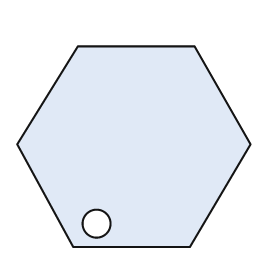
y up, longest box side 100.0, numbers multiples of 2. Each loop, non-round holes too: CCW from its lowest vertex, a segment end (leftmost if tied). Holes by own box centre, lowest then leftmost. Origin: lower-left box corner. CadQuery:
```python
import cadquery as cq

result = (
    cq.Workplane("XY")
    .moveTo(24.0, 0.0)
    .lineTo(74.0, 0.0)
    .lineTo(100.0, 44.0)
    .lineTo(76.0, 86.0)
    .lineTo(26.0, 86.0)
    .lineTo(0.0, 44.0)
    .close()
    .moveTo(34.0, 10.0)
    .circle(6.0)
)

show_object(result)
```